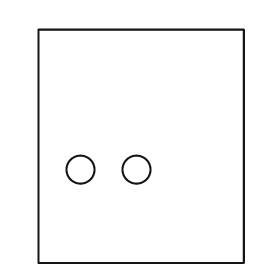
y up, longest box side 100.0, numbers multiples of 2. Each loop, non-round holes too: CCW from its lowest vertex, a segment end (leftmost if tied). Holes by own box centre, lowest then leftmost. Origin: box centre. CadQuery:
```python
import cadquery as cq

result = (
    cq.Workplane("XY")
    .moveTo(-44.0, -50.0)
    .lineTo(44.0, -50.0)
    .lineTo(44.0, 50.0)
    .lineTo(-44.0, 50.0)
    .close()
    .moveTo(-26.0, -10.0)
    .circle(6.0)
    .moveTo(-2.0, -10.0)
    .circle(6.0)
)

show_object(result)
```